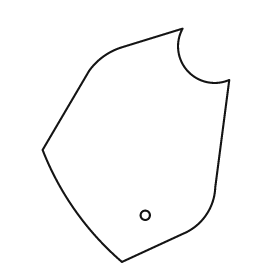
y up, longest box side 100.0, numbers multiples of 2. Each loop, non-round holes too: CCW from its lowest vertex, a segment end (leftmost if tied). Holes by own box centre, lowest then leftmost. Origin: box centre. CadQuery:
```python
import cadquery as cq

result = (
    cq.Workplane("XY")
    .moveTo(-6.0, -50.0)
    .lineTo(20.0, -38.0)
    .threePointArc((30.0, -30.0), (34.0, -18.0))
    .lineTo(40.0, 28.0)
    .threePointArc((22.0, 32.0), (20.0, 50.0))
    .lineTo(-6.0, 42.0)
    .threePointArc((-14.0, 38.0), (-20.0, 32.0))
    .lineTo(-40.0, -2.0)
    .threePointArc((-26.0, -28.0), (-6.0, -50.0))
    .close()
    .moveTo(4.0, -30.0)
    .circle(2.0)
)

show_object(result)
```